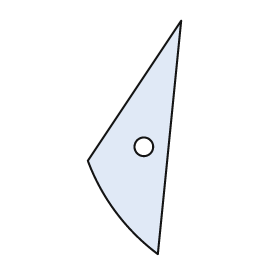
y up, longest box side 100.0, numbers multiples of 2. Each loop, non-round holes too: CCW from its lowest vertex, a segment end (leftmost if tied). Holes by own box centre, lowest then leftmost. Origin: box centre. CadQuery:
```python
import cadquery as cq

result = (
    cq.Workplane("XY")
    .moveTo(10.0, -50.0)
    .lineTo(20.0, 50.0)
    .lineTo(-20.0, -10.0)
    .threePointArc((-8.0, -32.0), (10.0, -50.0))
    .close()
    .moveTo(4.0, -4.0)
    .circle(4.0)
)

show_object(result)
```